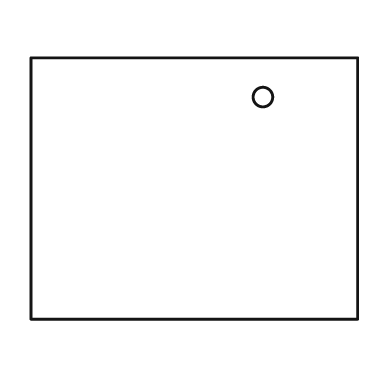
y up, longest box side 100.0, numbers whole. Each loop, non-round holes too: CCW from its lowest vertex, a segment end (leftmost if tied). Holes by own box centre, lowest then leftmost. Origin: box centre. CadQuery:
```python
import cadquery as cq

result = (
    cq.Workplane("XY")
    .moveTo(-50.0, -40.0)
    .lineTo(50.0, -40.0)
    .lineTo(50.0, 40.0)
    .lineTo(-50.0, 40.0)
    .close()
    .moveTo(21.0, 28.0)
    .circle(3.0)
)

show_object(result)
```